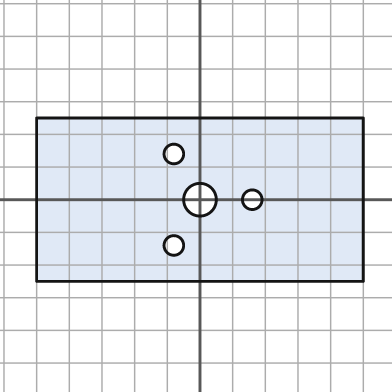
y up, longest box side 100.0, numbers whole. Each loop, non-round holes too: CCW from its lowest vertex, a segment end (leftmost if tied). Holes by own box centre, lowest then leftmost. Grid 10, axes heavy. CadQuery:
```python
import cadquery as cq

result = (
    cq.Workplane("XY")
    .moveTo(-50.0, -25.0)
    .lineTo(50.0, -25.0)
    .lineTo(50.0, 25.0)
    .lineTo(-50.0, 25.0)
    .close()
    .moveTo(-8.0, -14.0)
    .circle(3.0)
    .moveTo(0.0, 0.0)
    .circle(5.0)
    .moveTo(16.0, 0.0)
    .circle(3.0)
    .moveTo(-8.0, 14.0)
    .circle(3.0)
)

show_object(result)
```